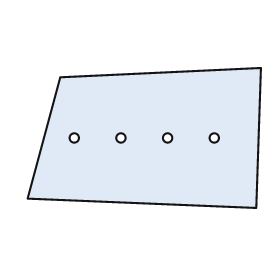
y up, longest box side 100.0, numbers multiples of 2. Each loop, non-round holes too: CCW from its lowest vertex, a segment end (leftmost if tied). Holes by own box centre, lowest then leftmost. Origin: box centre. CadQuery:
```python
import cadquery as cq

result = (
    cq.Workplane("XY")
    .moveTo(48.0, -30.0)
    .lineTo(50.0, 30.0)
    .lineTo(-36.0, 26.0)
    .lineTo(-50.0, -26.0)
    .close()
    .moveTo(-30.0, 0.0)
    .circle(2.0)
    .moveTo(-10.0, 0.0)
    .circle(2.0)
    .moveTo(10.0, 0.0)
    .circle(2.0)
    .moveTo(30.0, 0.0)
    .circle(2.0)
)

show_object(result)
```